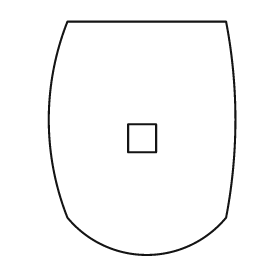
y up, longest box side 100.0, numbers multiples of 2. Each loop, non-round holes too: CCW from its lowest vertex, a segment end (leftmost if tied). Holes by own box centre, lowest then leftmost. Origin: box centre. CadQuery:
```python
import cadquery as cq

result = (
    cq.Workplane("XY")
    .moveTo(-32.0, -34.0)
    .threePointArc((2.0, -50.0), (36.0, -34.0))
    .threePointArc((40.0, 8.0), (36.0, 50.0))
    .lineTo(-32.0, 50.0)
    .threePointArc((-40.0, 8.0), (-32.0, -34.0))
    .close()
    .moveTo(-6.0, -6.0)
    .lineTo(6.0, -6.0)
    .lineTo(6.0, 6.0)
    .lineTo(-6.0, 6.0)
    .close()
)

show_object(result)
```